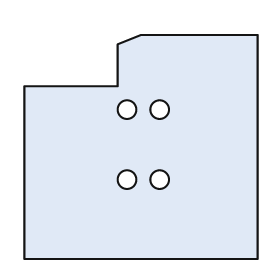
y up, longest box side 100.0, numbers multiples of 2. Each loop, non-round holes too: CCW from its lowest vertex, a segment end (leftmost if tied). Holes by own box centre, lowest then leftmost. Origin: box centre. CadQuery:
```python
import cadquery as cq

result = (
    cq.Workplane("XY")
    .moveTo(-50.0, -48.0)
    .lineTo(50.0, -48.0)
    .lineTo(50.0, 48.0)
    .lineTo(0.0, 48.0)
    .lineTo(-10.0, 44.0)
    .lineTo(-10.0, 26.0)
    .lineTo(-50.0, 26.0)
    .close()
    .moveTo(-6.0, -14.0)
    .circle(4.0)
    .moveTo(8.0, -14.0)
    .circle(4.0)
    .moveTo(-6.0, 16.0)
    .circle(4.0)
    .moveTo(8.0, 16.0)
    .circle(4.0)
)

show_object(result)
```